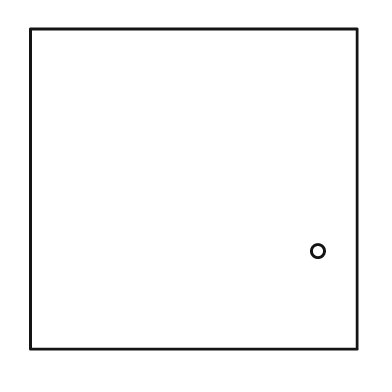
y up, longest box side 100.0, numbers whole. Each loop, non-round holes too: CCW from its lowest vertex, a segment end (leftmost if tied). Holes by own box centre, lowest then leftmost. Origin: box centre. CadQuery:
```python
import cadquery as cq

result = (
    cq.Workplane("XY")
    .moveTo(-50.0, -49.0)
    .lineTo(50.0, -49.0)
    .lineTo(50.0, 49.0)
    .lineTo(-50.0, 49.0)
    .close()
    .moveTo(38.0, -19.0)
    .circle(2.0)
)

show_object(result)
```